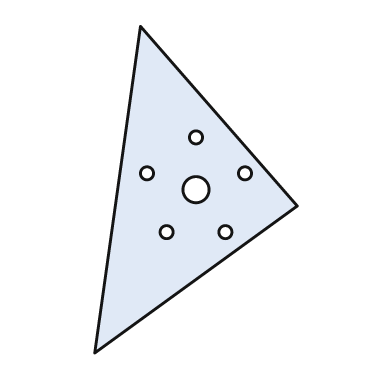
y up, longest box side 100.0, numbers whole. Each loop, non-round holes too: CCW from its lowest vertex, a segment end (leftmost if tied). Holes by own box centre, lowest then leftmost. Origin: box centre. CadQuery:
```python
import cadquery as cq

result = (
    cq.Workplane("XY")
    .moveTo(-31.0, -50.0)
    .lineTo(31.0, -5.0)
    .lineTo(-17.0, 50.0)
    .close()
    .moveTo(-9.0, -13.0)
    .circle(2.0)
    .moveTo(9.0, -13.0)
    .circle(2.0)
    .moveTo(0.0, 0.0)
    .circle(4.0)
    .moveTo(-15.0, 5.0)
    .circle(2.0)
    .moveTo(15.0, 5.0)
    .circle(2.0)
    .moveTo(0.0, 16.0)
    .circle(2.0)
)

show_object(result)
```